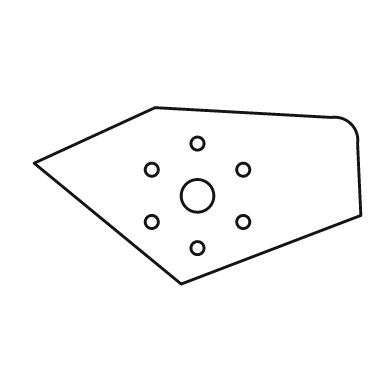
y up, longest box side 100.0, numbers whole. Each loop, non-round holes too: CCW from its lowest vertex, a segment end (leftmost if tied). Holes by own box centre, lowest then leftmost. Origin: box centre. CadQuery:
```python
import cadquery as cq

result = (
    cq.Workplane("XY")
    .moveTo(-5.0, -27.0)
    .lineTo(50.0, -6.0)
    .lineTo(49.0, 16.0)
    .threePointArc((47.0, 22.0), (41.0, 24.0))
    .lineTo(-13.0, 27.0)
    .lineTo(-50.0, 10.0)
    .close()
    .moveTo(0.0, -16.0)
    .circle(2.0)
    .moveTo(-14.0, -8.0)
    .circle(2.0)
    .moveTo(14.0, -8.0)
    .circle(2.0)
    .moveTo(0.0, 0.0)
    .circle(5.0)
    .moveTo(-14.0, 8.0)
    .circle(2.0)
    .moveTo(14.0, 8.0)
    .circle(2.0)
    .moveTo(0.0, 16.0)
    .circle(2.0)
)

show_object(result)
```